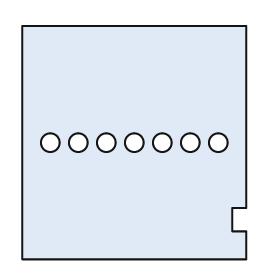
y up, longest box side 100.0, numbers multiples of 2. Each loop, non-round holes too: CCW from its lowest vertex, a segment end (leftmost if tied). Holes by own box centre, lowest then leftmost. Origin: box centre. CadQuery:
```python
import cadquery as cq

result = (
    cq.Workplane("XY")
    .moveTo(-48.0, -50.0)
    .lineTo(48.0, -50.0)
    .lineTo(48.0, -38.0)
    .lineTo(42.0, -38.0)
    .lineTo(42.0, -28.0)
    .lineTo(48.0, -28.0)
    .lineTo(48.0, 50.0)
    .lineTo(-48.0, 50.0)
    .close()
    .moveTo(-36.0, 0.0)
    .circle(4.0)
    .moveTo(-24.0, 0.0)
    .circle(4.0)
    .moveTo(-12.0, 0.0)
    .circle(4.0)
    .moveTo(0.0, 0.0)
    .circle(4.0)
    .moveTo(12.0, 0.0)
    .circle(4.0)
    .moveTo(24.0, 0.0)
    .circle(4.0)
    .moveTo(36.0, 0.0)
    .circle(4.0)
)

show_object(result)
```